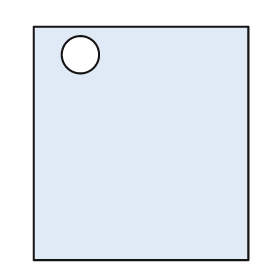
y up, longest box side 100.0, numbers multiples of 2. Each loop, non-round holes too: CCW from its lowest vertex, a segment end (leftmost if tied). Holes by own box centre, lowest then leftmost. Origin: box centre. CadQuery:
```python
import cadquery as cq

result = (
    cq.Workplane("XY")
    .moveTo(-46.0, -50.0)
    .lineTo(46.0, -50.0)
    .lineTo(46.0, 50.0)
    .lineTo(-46.0, 50.0)
    .close()
    .moveTo(-26.0, 38.0)
    .circle(8.0)
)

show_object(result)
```